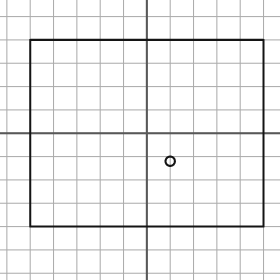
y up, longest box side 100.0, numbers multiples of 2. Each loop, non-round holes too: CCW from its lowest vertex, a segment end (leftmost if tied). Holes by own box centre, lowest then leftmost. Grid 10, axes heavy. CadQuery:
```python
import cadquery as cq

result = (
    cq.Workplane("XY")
    .moveTo(-50.0, -40.0)
    .lineTo(50.0, -40.0)
    .lineTo(50.0, 40.0)
    .lineTo(-50.0, 40.0)
    .close()
    .moveTo(10.0, -12.0)
    .circle(2.0)
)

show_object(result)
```